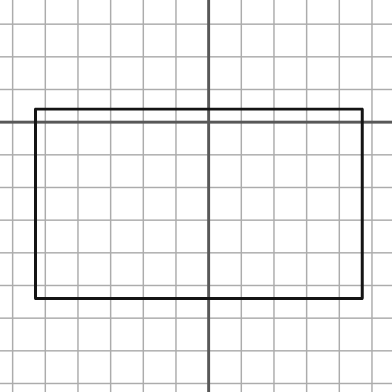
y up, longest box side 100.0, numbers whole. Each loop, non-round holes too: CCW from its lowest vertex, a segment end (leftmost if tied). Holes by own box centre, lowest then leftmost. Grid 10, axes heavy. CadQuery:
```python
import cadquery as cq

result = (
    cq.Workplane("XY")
    .moveTo(-53.0, -54.0)
    .lineTo(47.0, -54.0)
    .lineTo(47.0, 4.0)
    .lineTo(-53.0, 4.0)
    .close()
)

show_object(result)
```